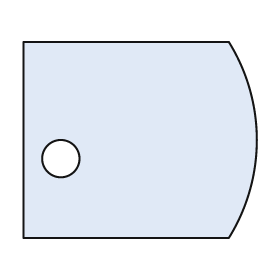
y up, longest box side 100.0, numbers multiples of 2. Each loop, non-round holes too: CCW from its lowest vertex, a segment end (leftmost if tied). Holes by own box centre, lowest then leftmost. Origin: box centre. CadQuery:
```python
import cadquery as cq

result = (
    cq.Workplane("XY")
    .moveTo(-50.0, -42.0)
    .lineTo(38.0, -42.0)
    .threePointArc((50.0, 0.0), (38.0, 42.0))
    .lineTo(-50.0, 42.0)
    .close()
    .moveTo(-34.0, -8.0)
    .circle(8.0)
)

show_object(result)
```